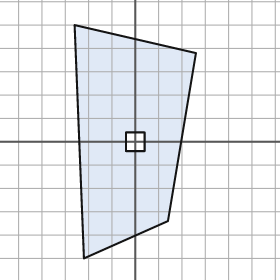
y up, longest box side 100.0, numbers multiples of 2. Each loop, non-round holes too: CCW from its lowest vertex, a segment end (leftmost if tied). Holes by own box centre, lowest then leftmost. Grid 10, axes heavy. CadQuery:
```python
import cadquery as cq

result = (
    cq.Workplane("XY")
    .moveTo(-22.0, -50.0)
    .lineTo(14.0, -34.0)
    .lineTo(26.0, 38.0)
    .lineTo(-26.0, 50.0)
    .close()
    .moveTo(-4.0, -4.0)
    .lineTo(4.0, -4.0)
    .lineTo(4.0, 4.0)
    .lineTo(-4.0, 4.0)
    .close()
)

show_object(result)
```